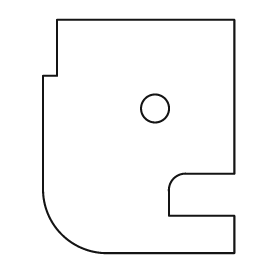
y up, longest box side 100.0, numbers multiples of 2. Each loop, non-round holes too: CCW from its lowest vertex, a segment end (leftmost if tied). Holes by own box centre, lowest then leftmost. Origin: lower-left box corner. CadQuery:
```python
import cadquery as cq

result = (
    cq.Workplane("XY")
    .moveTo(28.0, 0.0)
    .lineTo(82.0, 0.0)
    .lineTo(82.0, 16.0)
    .lineTo(54.0, 16.0)
    .lineTo(54.0, 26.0)
    .threePointArc((56.0, 32.0), (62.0, 34.0))
    .lineTo(82.0, 34.0)
    .lineTo(82.0, 100.0)
    .lineTo(6.0, 100.0)
    .lineTo(6.0, 76.0)
    .lineTo(0.0, 76.0)
    .lineTo(0.0, 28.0)
    .threePointArc((8.0, 8.0), (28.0, 0.0))
    .close()
    .moveTo(48.0, 62.0)
    .circle(6.0)
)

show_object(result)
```